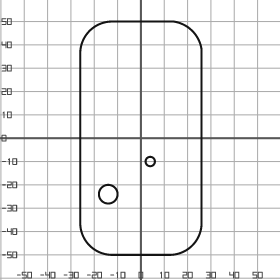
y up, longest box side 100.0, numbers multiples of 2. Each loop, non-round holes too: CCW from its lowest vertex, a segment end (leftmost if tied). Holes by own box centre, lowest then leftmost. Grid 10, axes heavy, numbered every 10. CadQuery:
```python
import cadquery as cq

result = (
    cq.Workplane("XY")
    .moveTo(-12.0, -50.0)
    .lineTo(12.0, -50.0)
    .threePointArc((22.0, -46.0), (26.0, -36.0))
    .lineTo(26.0, 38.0)
    .threePointArc((22.0, 46.0), (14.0, 50.0))
    .lineTo(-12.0, 50.0)
    .threePointArc((-22.0, 46.0), (-26.0, 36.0))
    .lineTo(-26.0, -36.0)
    .threePointArc((-22.0, -46.0), (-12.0, -50.0))
    .close()
    .moveTo(-14.0, -24.0)
    .circle(4.0)
    .moveTo(4.0, -10.0)
    .circle(2.0)
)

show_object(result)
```